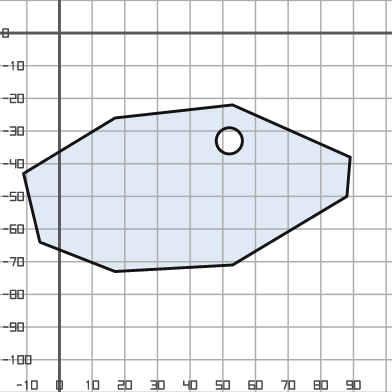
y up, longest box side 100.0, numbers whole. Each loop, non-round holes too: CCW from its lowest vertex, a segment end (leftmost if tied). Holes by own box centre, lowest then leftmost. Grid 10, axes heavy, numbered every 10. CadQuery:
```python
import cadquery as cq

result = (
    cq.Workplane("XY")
    .moveTo(17.0, -73.0)
    .lineTo(53.0, -71.0)
    .lineTo(88.0, -50.0)
    .lineTo(89.0, -38.0)
    .lineTo(53.0, -22.0)
    .lineTo(17.0, -26.0)
    .lineTo(-11.0, -43.0)
    .lineTo(-6.0, -64.0)
    .close()
    .moveTo(52.0, -33.0)
    .circle(4.0)
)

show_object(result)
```